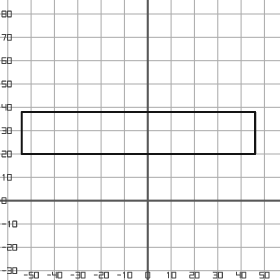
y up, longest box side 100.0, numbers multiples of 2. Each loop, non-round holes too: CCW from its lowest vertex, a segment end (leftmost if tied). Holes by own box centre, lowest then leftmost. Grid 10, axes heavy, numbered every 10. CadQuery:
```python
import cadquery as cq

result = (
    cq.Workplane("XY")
    .moveTo(-54.0, 20.0)
    .lineTo(46.0, 20.0)
    .lineTo(46.0, 38.0)
    .lineTo(-54.0, 38.0)
    .close()
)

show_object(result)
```